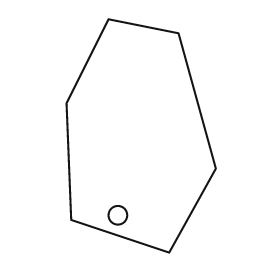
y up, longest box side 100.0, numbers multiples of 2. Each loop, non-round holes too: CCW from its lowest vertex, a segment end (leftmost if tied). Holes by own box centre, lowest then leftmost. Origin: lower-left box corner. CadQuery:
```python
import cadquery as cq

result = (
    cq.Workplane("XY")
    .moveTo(44.0, 0.0)
    .lineTo(64.0, 36.0)
    .lineTo(48.0, 94.0)
    .lineTo(18.0, 100.0)
    .lineTo(0.0, 64.0)
    .lineTo(2.0, 14.0)
    .close()
    .moveTo(22.0, 16.0)
    .circle(4.0)
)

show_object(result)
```